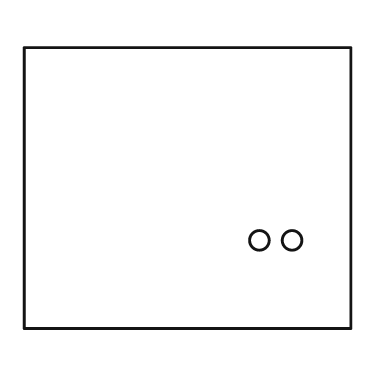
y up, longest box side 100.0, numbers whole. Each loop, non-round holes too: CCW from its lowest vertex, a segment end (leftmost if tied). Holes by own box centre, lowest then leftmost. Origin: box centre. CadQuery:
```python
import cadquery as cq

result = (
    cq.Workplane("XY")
    .moveTo(-50.0, -43.0)
    .lineTo(50.0, -43.0)
    .lineTo(50.0, 43.0)
    .lineTo(-50.0, 43.0)
    .close()
    .moveTo(22.0, -16.0)
    .circle(3.0)
    .moveTo(32.0, -16.0)
    .circle(3.0)
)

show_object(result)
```